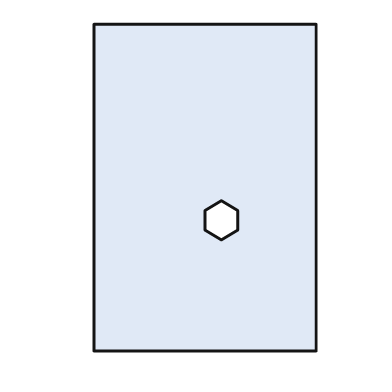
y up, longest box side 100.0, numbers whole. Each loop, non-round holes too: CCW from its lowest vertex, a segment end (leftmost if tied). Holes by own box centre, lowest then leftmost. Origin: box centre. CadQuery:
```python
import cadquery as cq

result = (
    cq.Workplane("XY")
    .moveTo(-34.0, -50.0)
    .lineTo(34.0, -50.0)
    .lineTo(34.0, 50.0)
    .lineTo(-34.0, 50.0)
    .close()
    .moveTo(5.0, -16.0)
    .lineTo(10.0, -13.0)
    .lineTo(10.0, -7.0)
    .lineTo(5.0, -4.0)
    .lineTo(0.0, -7.0)
    .lineTo(0.0, -13.0)
    .close()
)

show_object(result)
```